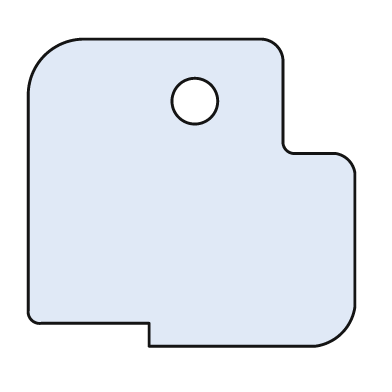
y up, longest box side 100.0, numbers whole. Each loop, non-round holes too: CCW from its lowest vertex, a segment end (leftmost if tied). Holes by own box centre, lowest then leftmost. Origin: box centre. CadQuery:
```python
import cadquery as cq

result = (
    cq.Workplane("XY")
    .moveTo(-13.0, -47.0)
    .lineTo(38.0, -47.0)
    .threePointArc((46.0, -43.0), (50.0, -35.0))
    .lineTo(50.0, 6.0)
    .threePointArc((48.0, 10.0), (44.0, 12.0))
    .lineTo(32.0, 12.0)
    .threePointArc((29.0, 13.0), (28.0, 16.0))
    .lineTo(28.0, 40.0)
    .threePointArc((26.0, 45.0), (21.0, 47.0))
    .lineTo(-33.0, 47.0)
    .threePointArc((-45.0, 42.0), (-50.0, 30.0))
    .lineTo(-50.0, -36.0)
    .threePointArc((-49.0, -39.0), (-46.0, -40.0))
    .lineTo(-13.0, -40.0)
    .close()
    .moveTo(1.0, 28.0)
    .circle(7.0)
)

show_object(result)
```